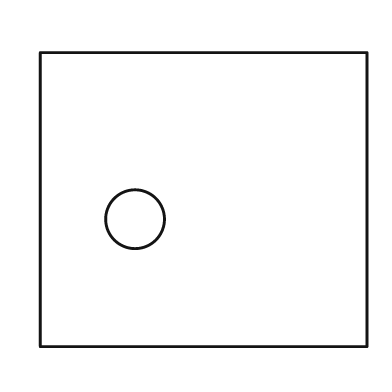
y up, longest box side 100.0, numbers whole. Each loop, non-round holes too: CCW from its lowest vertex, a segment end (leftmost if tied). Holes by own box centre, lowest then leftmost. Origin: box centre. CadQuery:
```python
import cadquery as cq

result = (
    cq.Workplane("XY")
    .moveTo(-50.0, -45.0)
    .lineTo(50.0, -45.0)
    .lineTo(50.0, 45.0)
    .lineTo(-50.0, 45.0)
    .close()
    .moveTo(-21.0, -6.0)
    .circle(9.0)
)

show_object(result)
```